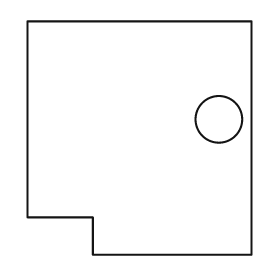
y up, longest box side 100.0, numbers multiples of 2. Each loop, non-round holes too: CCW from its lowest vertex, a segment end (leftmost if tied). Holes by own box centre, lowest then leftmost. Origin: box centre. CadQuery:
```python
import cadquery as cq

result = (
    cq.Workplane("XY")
    .moveTo(-20.0, -50.0)
    .lineTo(48.0, -50.0)
    .lineTo(48.0, 50.0)
    .lineTo(-48.0, 50.0)
    .lineTo(-48.0, -34.0)
    .lineTo(-20.0, -34.0)
    .close()
    .moveTo(34.0, 8.0)
    .circle(10.0)
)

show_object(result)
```